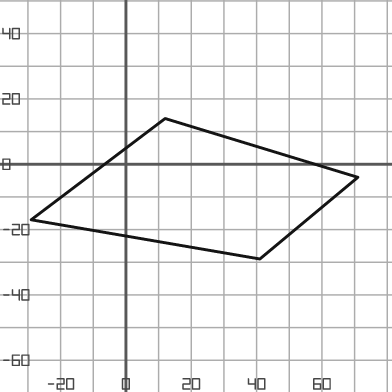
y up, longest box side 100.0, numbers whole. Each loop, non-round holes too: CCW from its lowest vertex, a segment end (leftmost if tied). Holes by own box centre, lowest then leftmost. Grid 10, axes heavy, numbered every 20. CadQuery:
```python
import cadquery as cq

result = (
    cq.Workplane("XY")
    .moveTo(41.0, -29.0)
    .lineTo(71.0, -4.0)
    .lineTo(12.0, 14.0)
    .lineTo(-29.0, -17.0)
    .close()
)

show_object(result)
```